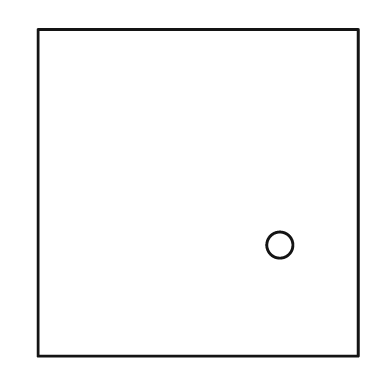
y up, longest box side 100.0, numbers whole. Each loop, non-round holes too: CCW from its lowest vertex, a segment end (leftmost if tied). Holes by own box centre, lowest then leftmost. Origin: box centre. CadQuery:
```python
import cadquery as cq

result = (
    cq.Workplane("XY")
    .moveTo(-49.0, -50.0)
    .lineTo(49.0, -50.0)
    .lineTo(49.0, 50.0)
    .lineTo(-49.0, 50.0)
    .close()
    .moveTo(25.0, -16.0)
    .circle(4.0)
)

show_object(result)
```